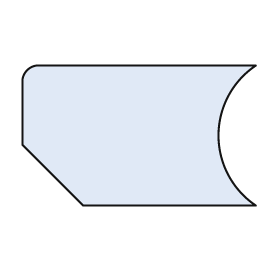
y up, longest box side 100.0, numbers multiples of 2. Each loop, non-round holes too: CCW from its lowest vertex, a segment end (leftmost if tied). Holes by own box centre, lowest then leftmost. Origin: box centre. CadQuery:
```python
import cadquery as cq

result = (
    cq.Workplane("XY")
    .moveTo(-24.0, -30.0)
    .lineTo(50.0, -30.0)
    .threePointArc((34.0, 0.0), (50.0, 30.0))
    .lineTo(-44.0, 30.0)
    .threePointArc((-48.0, 28.0), (-50.0, 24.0))
    .lineTo(-50.0, -4.0)
    .close()
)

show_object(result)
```